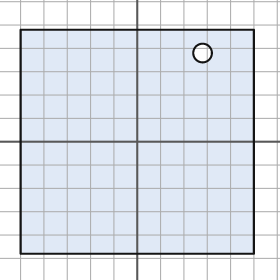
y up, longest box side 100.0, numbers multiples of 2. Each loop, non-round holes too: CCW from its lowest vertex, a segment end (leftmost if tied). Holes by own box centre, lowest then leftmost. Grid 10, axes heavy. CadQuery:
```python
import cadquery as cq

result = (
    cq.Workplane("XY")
    .moveTo(-50.0, -48.0)
    .lineTo(50.0, -48.0)
    .lineTo(50.0, 48.0)
    .lineTo(-50.0, 48.0)
    .close()
    .moveTo(28.0, 38.0)
    .circle(4.0)
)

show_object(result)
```